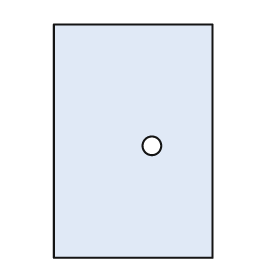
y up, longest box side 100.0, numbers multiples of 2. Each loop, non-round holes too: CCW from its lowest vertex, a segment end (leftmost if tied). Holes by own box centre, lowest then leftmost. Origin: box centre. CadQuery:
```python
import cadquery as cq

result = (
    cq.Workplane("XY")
    .moveTo(-34.0, -50.0)
    .lineTo(34.0, -50.0)
    .lineTo(34.0, 50.0)
    .lineTo(-34.0, 50.0)
    .close()
    .moveTo(8.0, -2.0)
    .circle(4.0)
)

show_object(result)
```